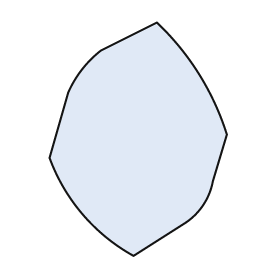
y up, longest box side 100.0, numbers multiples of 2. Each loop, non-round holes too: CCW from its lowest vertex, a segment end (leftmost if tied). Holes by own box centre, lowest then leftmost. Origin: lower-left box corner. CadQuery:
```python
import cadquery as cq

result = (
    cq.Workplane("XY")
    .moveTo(36.0, 0.0)
    .lineTo(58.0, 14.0)
    .threePointArc((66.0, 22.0), (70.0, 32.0))
    .lineTo(76.0, 52.0)
    .threePointArc((64.0, 78.0), (46.0, 100.0))
    .lineTo(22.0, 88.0)
    .threePointArc((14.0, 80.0), (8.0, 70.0))
    .lineTo(0.0, 42.0)
    .threePointArc((14.0, 18.0), (36.0, 0.0))
    .close()
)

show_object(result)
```